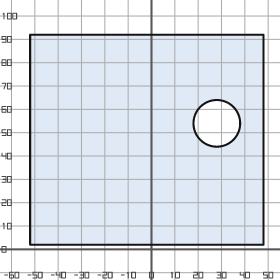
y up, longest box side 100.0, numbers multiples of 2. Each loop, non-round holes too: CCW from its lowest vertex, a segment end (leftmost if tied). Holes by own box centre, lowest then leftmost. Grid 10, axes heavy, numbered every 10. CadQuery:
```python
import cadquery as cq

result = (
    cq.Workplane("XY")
    .moveTo(-52.0, 2.0)
    .lineTo(48.0, 2.0)
    .lineTo(48.0, 92.0)
    .lineTo(-52.0, 92.0)
    .close()
    .moveTo(28.0, 54.0)
    .circle(10.0)
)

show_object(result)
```